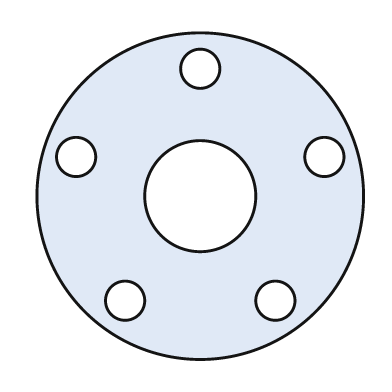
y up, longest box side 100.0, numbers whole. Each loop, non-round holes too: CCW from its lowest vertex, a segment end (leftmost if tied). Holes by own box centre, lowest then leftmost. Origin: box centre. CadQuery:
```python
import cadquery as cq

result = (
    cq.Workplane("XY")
    .moveTo(0.0, 0.0)
    .circle(50.0)
    .moveTo(-23.0, -32.0)
    .circle(6.0)
    .moveTo(23.0, -32.0)
    .circle(6.0)
    .moveTo(0.0, 0.0)
    .circle(17.0)
    .moveTo(-38.0, 12.0)
    .circle(6.0)
    .moveTo(38.0, 12.0)
    .circle(6.0)
    .moveTo(0.0, 39.0)
    .circle(6.0)
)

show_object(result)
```